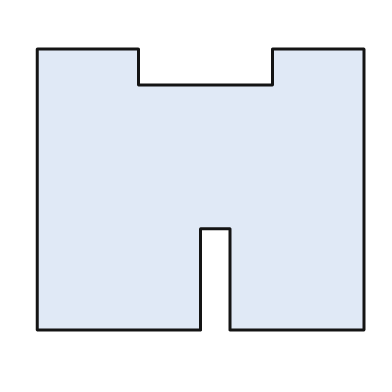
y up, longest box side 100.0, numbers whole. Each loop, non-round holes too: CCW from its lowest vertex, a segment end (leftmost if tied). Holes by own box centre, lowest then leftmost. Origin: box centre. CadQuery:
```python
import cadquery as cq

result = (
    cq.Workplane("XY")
    .moveTo(-50.0, -43.0)
    .lineTo(0.0, -43.0)
    .lineTo(0.0, -12.0)
    .lineTo(9.0, -12.0)
    .lineTo(9.0, -43.0)
    .lineTo(50.0, -43.0)
    .lineTo(50.0, 43.0)
    .lineTo(22.0, 43.0)
    .lineTo(22.0, 32.0)
    .lineTo(-19.0, 32.0)
    .lineTo(-19.0, 43.0)
    .lineTo(-50.0, 43.0)
    .close()
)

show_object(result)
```